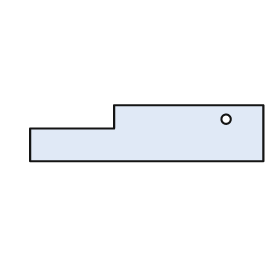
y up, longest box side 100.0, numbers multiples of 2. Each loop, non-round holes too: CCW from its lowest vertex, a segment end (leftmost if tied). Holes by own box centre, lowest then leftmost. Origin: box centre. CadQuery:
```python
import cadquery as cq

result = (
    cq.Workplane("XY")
    .moveTo(-50.0, -12.0)
    .lineTo(50.0, -12.0)
    .lineTo(50.0, 12.0)
    .lineTo(-14.0, 12.0)
    .lineTo(-14.0, 2.0)
    .lineTo(-50.0, 2.0)
    .close()
    .moveTo(34.0, 6.0)
    .circle(2.0)
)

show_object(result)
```